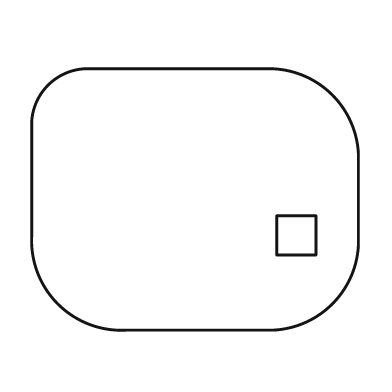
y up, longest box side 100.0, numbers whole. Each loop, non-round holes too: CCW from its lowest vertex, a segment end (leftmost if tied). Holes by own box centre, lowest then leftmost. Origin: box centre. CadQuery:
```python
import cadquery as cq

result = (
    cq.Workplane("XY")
    .moveTo(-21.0, -40.0)
    .lineTo(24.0, -40.0)
    .threePointArc((42.0, -32.0), (50.0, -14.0))
    .lineTo(50.0, 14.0)
    .threePointArc((42.0, 32.0), (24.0, 40.0))
    .lineTo(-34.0, 40.0)
    .threePointArc((-45.0, 35.0), (-50.0, 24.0))
    .lineTo(-50.0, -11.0)
    .threePointArc((-42.0, -32.0), (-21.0, -40.0))
    .close()
    .moveTo(25.0, -17.0)
    .lineTo(37.0, -17.0)
    .lineTo(37.0, -5.0)
    .lineTo(25.0, -5.0)
    .close()
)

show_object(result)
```